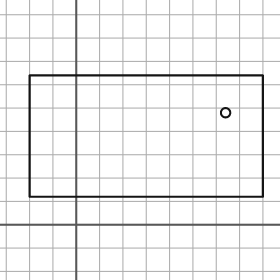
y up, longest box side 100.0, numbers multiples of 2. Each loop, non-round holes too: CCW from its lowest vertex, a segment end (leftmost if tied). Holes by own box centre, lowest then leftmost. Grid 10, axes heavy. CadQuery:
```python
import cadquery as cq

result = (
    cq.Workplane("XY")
    .moveTo(-20.0, 12.0)
    .lineTo(80.0, 12.0)
    .lineTo(80.0, 64.0)
    .lineTo(-20.0, 64.0)
    .close()
    .moveTo(64.0, 48.0)
    .circle(2.0)
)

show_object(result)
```